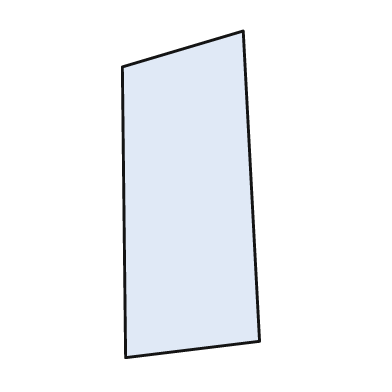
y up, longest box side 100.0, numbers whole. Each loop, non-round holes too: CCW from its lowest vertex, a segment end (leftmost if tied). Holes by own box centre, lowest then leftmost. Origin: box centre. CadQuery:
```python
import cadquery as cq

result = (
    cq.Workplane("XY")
    .moveTo(-20.0, -50.0)
    .lineTo(21.0, -45.0)
    .lineTo(16.0, 50.0)
    .lineTo(-21.0, 39.0)
    .close()
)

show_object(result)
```